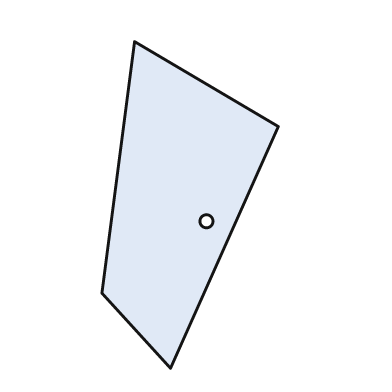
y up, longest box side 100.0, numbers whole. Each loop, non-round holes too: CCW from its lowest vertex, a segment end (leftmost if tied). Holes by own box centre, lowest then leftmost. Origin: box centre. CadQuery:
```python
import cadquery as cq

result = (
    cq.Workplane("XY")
    .moveTo(-6.0, -50.0)
    .lineTo(27.0, 24.0)
    .lineTo(-17.0, 50.0)
    .lineTo(-27.0, -27.0)
    .close()
    .moveTo(5.0, -5.0)
    .circle(2.0)
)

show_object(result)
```